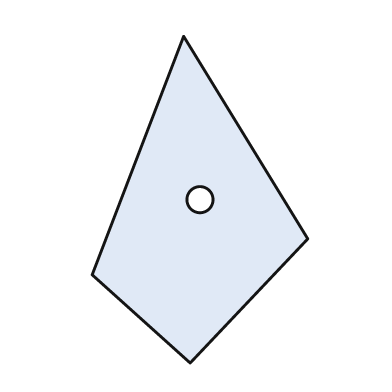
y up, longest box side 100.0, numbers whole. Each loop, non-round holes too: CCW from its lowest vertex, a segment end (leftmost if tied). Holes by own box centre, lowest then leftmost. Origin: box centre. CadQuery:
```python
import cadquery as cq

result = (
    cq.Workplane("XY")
    .moveTo(-3.0, -50.0)
    .lineTo(33.0, -12.0)
    .lineTo(-5.0, 50.0)
    .lineTo(-33.0, -23.0)
    .close()
    .moveTo(0.0, 0.0)
    .circle(4.0)
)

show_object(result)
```